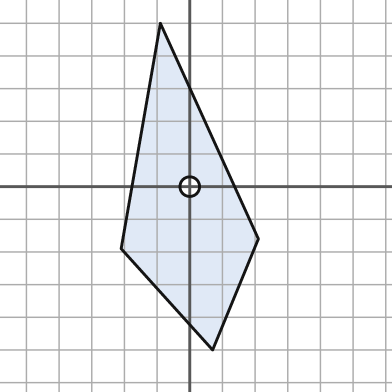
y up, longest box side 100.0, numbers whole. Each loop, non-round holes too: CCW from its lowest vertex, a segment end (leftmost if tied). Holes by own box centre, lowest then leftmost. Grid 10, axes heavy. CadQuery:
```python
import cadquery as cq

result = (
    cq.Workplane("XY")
    .moveTo(7.0, -50.0)
    .lineTo(21.0, -16.0)
    .lineTo(-9.0, 50.0)
    .lineTo(-21.0, -19.0)
    .close()
    .moveTo(0.0, 0.0)
    .circle(3.0)
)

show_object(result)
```